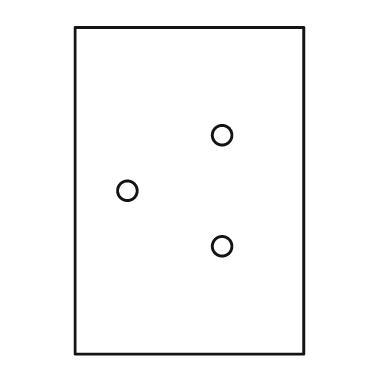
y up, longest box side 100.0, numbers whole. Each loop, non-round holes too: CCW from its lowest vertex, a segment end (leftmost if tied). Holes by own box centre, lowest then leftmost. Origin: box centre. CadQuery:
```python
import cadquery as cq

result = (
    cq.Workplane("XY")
    .moveTo(-35.0, -50.0)
    .lineTo(35.0, -50.0)
    .lineTo(35.0, 50.0)
    .lineTo(-35.0, 50.0)
    .close()
    .moveTo(10.0, -17.0)
    .circle(3.0)
    .moveTo(-19.0, 0.0)
    .circle(3.0)
    .moveTo(10.0, 17.0)
    .circle(3.0)
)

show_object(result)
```